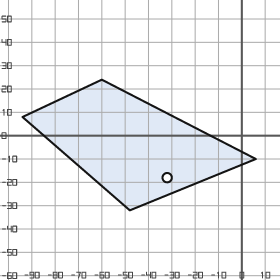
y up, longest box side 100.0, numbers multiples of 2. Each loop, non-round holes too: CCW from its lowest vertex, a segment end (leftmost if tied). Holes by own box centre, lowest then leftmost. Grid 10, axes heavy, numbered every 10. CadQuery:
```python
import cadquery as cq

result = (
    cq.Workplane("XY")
    .moveTo(-48.0, -32.0)
    .lineTo(6.0, -10.0)
    .lineTo(-60.0, 24.0)
    .lineTo(-94.0, 8.0)
    .close()
    .moveTo(-32.0, -18.0)
    .circle(2.0)
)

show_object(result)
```